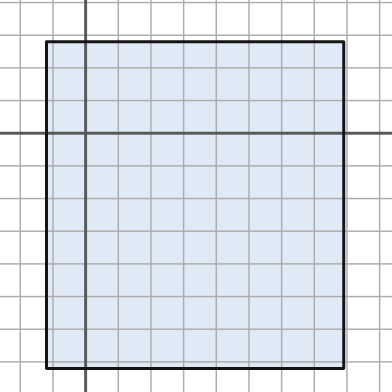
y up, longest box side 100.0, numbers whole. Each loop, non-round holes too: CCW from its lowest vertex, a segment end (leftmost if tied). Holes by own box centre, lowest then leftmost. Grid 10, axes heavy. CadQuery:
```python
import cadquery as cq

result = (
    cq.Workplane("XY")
    .moveTo(-12.0, -72.0)
    .lineTo(79.0, -72.0)
    .lineTo(79.0, 28.0)
    .lineTo(-12.0, 28.0)
    .close()
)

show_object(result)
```